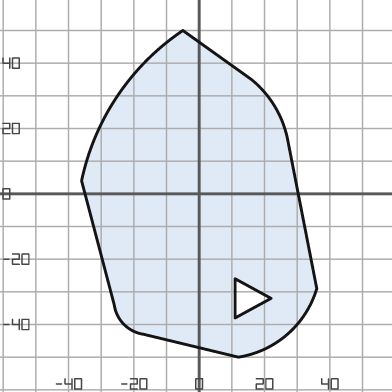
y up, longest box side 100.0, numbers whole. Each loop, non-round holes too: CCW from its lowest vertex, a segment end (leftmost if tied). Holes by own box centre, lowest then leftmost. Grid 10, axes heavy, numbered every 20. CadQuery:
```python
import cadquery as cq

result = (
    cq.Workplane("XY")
    .moveTo(12.0, -50.0)
    .threePointArc((27.0, -43.0), (36.0, -29.0))
    .lineTo(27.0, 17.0)
    .threePointArc((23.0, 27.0), (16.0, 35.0))
    .lineTo(-5.0, 50.0)
    .threePointArc((-25.0, 30.0), (-36.0, 4.0))
    .lineTo(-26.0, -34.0)
    .threePointArc((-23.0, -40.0), (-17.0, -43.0))
    .close()
    .moveTo(11.0, -38.0)
    .lineTo(22.0, -32.0)
    .lineTo(11.0, -26.0)
    .close()
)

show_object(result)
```